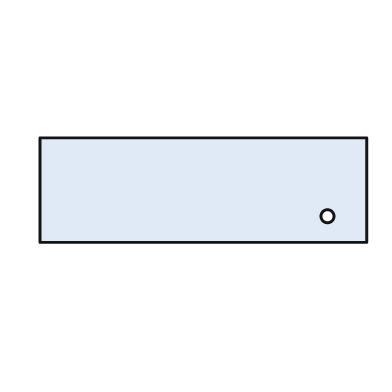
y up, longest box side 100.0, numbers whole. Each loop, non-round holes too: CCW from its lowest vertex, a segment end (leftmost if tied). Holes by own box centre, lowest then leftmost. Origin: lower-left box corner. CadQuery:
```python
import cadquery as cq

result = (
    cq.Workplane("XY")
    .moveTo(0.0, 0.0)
    .lineTo(100.0, 0.0)
    .lineTo(100.0, 32.0)
    .lineTo(0.0, 32.0)
    .close()
    .moveTo(88.0, 8.0)
    .circle(2.0)
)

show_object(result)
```